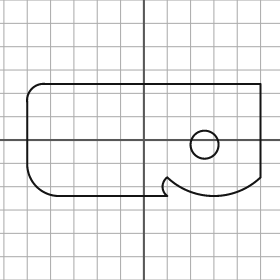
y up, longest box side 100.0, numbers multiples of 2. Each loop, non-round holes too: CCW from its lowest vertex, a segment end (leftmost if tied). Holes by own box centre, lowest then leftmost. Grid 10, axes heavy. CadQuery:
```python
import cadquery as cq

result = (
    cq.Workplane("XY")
    .moveTo(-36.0, -24.0)
    .lineTo(10.0, -24.0)
    .threePointArc((8.0, -20.0), (10.0, -16.0))
    .threePointArc((30.0, -24.0), (50.0, -16.0))
    .lineTo(50.0, 24.0)
    .lineTo(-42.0, 24.0)
    .threePointArc((-48.0, 22.0), (-50.0, 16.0))
    .lineTo(-50.0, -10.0)
    .threePointArc((-46.0, -20.0), (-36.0, -24.0))
    .close()
    .moveTo(26.0, -2.0)
    .circle(6.0)
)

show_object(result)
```